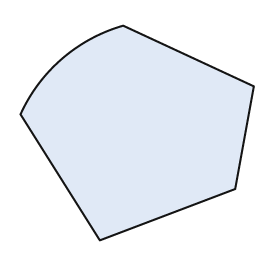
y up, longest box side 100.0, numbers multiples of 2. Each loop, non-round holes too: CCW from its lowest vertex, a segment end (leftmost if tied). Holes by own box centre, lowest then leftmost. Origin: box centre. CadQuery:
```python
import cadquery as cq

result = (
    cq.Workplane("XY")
    .moveTo(-16.0, -46.0)
    .lineTo(42.0, -24.0)
    .lineTo(50.0, 20.0)
    .lineTo(-6.0, 46.0)
    .threePointArc((-32.0, 32.0), (-50.0, 8.0))
    .close()
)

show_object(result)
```